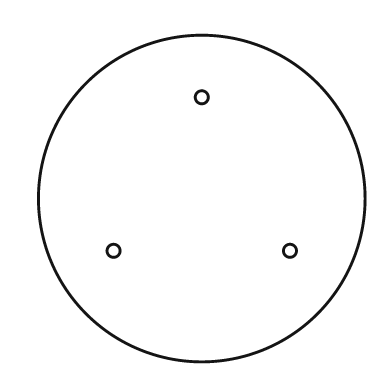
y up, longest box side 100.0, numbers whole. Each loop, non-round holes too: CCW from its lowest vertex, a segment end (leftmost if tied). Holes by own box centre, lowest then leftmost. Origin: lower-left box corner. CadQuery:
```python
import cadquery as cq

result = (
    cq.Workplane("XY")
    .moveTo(50.0, 50.0)
    .circle(50.0)
    .moveTo(23.0, 34.0)
    .circle(2.0)
    .moveTo(77.0, 34.0)
    .circle(2.0)
    .moveTo(50.0, 81.0)
    .circle(2.0)
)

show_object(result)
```